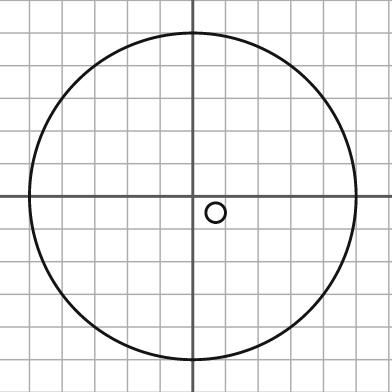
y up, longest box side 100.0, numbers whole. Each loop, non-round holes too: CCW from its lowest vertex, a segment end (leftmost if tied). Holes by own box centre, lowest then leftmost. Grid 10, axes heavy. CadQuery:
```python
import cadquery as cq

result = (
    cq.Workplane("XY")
    .moveTo(0.0, 0.0)
    .circle(50.0)
    .moveTo(7.0, -5.0)
    .circle(3.0)
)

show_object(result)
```